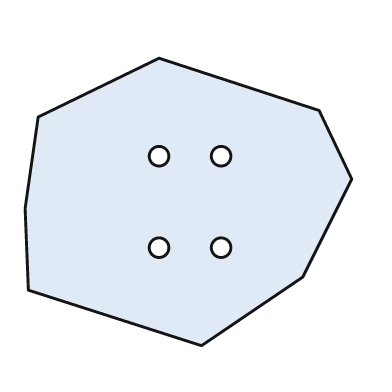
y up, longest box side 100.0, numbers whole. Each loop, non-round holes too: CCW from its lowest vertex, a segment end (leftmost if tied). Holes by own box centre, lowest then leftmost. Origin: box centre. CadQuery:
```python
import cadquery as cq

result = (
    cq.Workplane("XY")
    .moveTo(4.0, -44.0)
    .lineTo(35.0, -23.0)
    .lineTo(50.0, 7.0)
    .lineTo(40.0, 28.0)
    .lineTo(-9.0, 44.0)
    .lineTo(-46.0, 26.0)
    .lineTo(-50.0, -2.0)
    .lineTo(-49.0, -27.0)
    .close()
    .moveTo(-9.0, -14.0)
    .circle(3.0)
    .moveTo(10.0, -14.0)
    .circle(3.0)
    .moveTo(-9.0, 14.0)
    .circle(3.0)
    .moveTo(10.0, 14.0)
    .circle(3.0)
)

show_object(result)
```